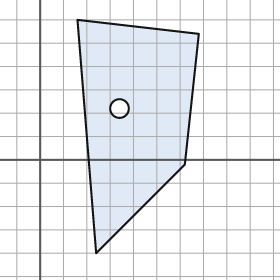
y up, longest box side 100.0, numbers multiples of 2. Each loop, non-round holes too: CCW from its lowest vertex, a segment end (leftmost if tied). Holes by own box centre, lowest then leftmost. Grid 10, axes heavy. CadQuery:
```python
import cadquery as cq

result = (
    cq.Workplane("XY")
    .moveTo(24.0, -40.0)
    .lineTo(62.0, -2.0)
    .lineTo(68.0, 54.0)
    .lineTo(16.0, 60.0)
    .close()
    .moveTo(34.0, 22.0)
    .circle(4.0)
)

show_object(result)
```